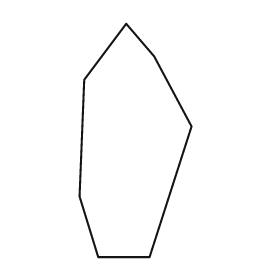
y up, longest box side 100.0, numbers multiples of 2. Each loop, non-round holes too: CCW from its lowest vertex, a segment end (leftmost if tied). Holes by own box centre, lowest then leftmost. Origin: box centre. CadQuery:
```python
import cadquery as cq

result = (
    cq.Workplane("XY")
    .moveTo(-16.0, -50.0)
    .lineTo(6.0, -50.0)
    .lineTo(24.0, 6.0)
    .lineTo(8.0, 36.0)
    .lineTo(-4.0, 50.0)
    .lineTo(-22.0, 26.0)
    .lineTo(-24.0, -24.0)
    .close()
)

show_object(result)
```